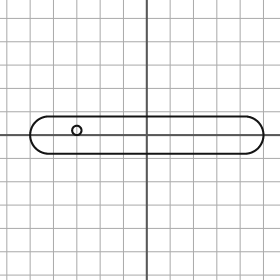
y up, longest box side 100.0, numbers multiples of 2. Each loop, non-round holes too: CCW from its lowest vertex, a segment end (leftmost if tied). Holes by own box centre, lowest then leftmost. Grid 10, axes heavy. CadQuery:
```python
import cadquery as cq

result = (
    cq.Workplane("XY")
    .moveTo(-42.0, -8.0)
    .lineTo(42.0, -8.0)
    .threePointArc((50.0, 0.0), (42.0, 8.0))
    .lineTo(-42.0, 8.0)
    .threePointArc((-50.0, 0.0), (-42.0, -8.0))
    .close()
    .moveTo(-30.0, 2.0)
    .circle(2.0)
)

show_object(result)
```